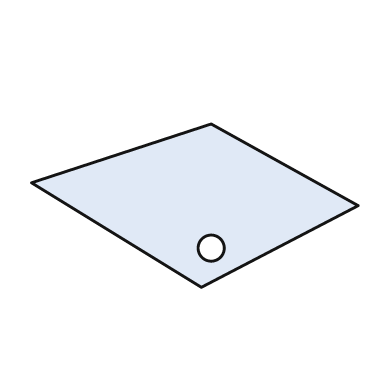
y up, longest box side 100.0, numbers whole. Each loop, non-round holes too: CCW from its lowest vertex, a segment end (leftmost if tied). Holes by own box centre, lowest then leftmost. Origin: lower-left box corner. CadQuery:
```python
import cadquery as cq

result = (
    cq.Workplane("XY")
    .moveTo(52.0, 0.0)
    .lineTo(100.0, 25.0)
    .lineTo(55.0, 50.0)
    .lineTo(0.0, 32.0)
    .close()
    .moveTo(55.0, 12.0)
    .circle(4.0)
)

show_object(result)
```